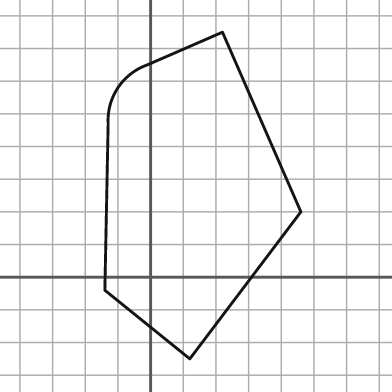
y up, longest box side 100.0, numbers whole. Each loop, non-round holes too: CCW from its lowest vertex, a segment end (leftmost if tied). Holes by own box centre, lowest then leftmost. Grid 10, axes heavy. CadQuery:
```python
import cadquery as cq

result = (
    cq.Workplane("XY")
    .moveTo(12.0, -25.0)
    .lineTo(46.0, 20.0)
    .lineTo(22.0, 75.0)
    .lineTo(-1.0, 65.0)
    .threePointArc((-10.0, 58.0), (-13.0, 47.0))
    .lineTo(-14.0, -4.0)
    .close()
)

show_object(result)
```